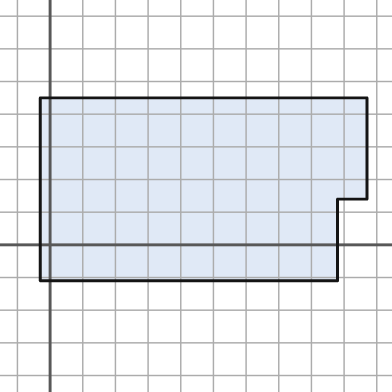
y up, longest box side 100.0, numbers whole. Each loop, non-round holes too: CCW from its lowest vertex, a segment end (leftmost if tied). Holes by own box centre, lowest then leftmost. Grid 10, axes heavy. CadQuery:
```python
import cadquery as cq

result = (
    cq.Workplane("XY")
    .moveTo(-3.0, -11.0)
    .lineTo(88.0, -11.0)
    .lineTo(88.0, 14.0)
    .lineTo(97.0, 14.0)
    .lineTo(97.0, 45.0)
    .lineTo(-3.0, 45.0)
    .close()
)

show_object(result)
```